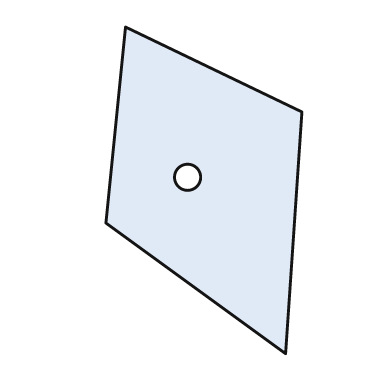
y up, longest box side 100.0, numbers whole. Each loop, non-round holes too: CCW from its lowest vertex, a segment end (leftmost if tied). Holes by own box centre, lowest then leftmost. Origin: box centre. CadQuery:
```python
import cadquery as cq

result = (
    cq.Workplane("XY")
    .moveTo(25.0, -50.0)
    .lineTo(30.0, 24.0)
    .lineTo(-24.0, 50.0)
    .lineTo(-30.0, -10.0)
    .close()
    .moveTo(-5.0, 4.0)
    .circle(4.0)
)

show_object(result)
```